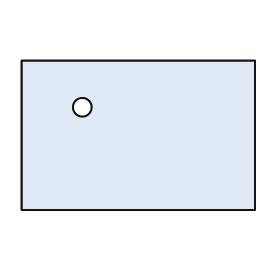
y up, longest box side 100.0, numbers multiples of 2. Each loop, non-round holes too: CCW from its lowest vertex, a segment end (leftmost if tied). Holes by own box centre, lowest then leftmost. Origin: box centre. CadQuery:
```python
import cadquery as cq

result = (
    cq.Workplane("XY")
    .moveTo(-50.0, -32.0)
    .lineTo(50.0, -32.0)
    .lineTo(50.0, 32.0)
    .lineTo(-50.0, 32.0)
    .close()
    .moveTo(-24.0, 12.0)
    .circle(4.0)
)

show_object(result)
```